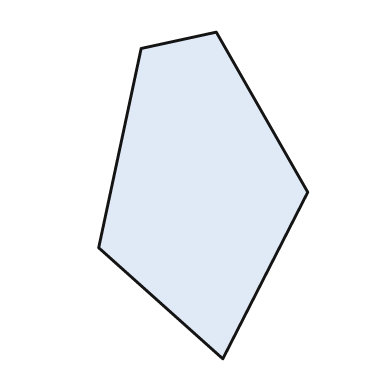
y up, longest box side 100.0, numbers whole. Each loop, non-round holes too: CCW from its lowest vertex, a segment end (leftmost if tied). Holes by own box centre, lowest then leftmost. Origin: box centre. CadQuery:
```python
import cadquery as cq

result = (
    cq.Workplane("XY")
    .moveTo(6.0, -50.0)
    .lineTo(32.0, 1.0)
    .lineTo(4.0, 50.0)
    .lineTo(-19.0, 45.0)
    .lineTo(-32.0, -16.0)
    .close()
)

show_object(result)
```